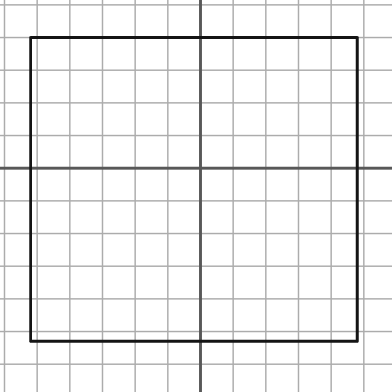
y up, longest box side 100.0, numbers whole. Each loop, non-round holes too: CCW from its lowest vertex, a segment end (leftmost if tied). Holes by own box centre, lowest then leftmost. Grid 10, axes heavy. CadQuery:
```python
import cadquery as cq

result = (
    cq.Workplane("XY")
    .moveTo(-52.0, -53.0)
    .lineTo(48.0, -53.0)
    .lineTo(48.0, 40.0)
    .lineTo(-52.0, 40.0)
    .close()
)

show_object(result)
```